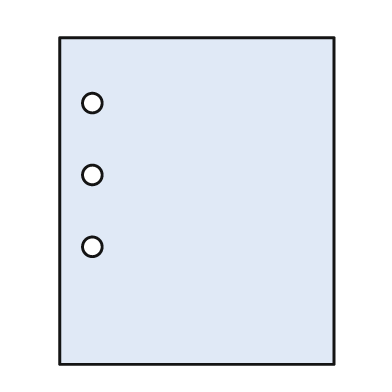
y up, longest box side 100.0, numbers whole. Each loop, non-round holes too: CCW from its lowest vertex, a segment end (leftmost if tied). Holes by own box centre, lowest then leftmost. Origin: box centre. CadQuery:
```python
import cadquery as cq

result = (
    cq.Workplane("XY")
    .moveTo(-42.0, -50.0)
    .lineTo(42.0, -50.0)
    .lineTo(42.0, 50.0)
    .lineTo(-42.0, 50.0)
    .close()
    .moveTo(-32.0, -14.0)
    .circle(3.0)
    .moveTo(-32.0, 8.0)
    .circle(3.0)
    .moveTo(-32.0, 30.0)
    .circle(3.0)
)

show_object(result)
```